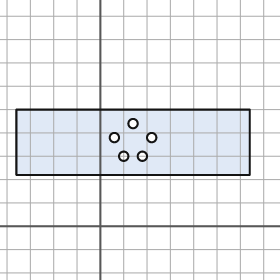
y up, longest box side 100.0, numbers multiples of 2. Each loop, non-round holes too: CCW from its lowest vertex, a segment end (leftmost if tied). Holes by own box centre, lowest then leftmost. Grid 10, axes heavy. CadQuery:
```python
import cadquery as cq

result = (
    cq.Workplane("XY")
    .moveTo(-36.0, 22.0)
    .lineTo(64.0, 22.0)
    .lineTo(64.0, 50.0)
    .lineTo(-36.0, 50.0)
    .close()
    .moveTo(10.0, 30.0)
    .circle(2.0)
    .moveTo(18.0, 30.0)
    .circle(2.0)
    .moveTo(6.0, 38.0)
    .circle(2.0)
    .moveTo(22.0, 38.0)
    .circle(2.0)
    .moveTo(14.0, 44.0)
    .circle(2.0)
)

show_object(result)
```